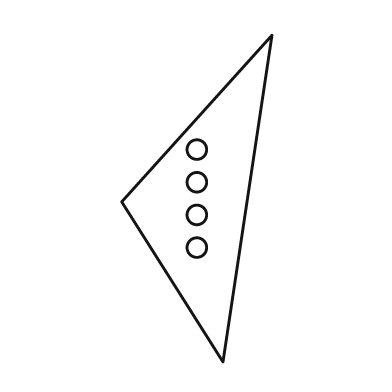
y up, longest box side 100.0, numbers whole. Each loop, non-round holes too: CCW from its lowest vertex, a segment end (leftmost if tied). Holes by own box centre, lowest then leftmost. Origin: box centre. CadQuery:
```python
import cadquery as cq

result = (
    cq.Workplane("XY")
    .moveTo(8.0, -50.0)
    .lineTo(23.0, 50.0)
    .lineTo(-23.0, -1.0)
    .close()
    .moveTo(0.0, -15.0)
    .circle(3.0)
    .moveTo(0.0, -5.0)
    .circle(3.0)
    .moveTo(0.0, 5.0)
    .circle(3.0)
    .moveTo(0.0, 15.0)
    .circle(3.0)
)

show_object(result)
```